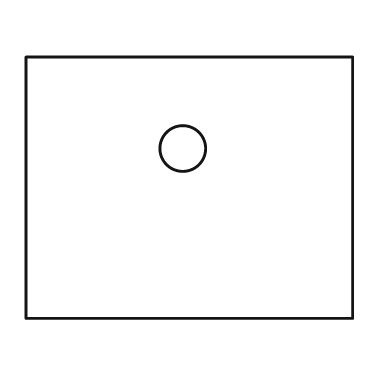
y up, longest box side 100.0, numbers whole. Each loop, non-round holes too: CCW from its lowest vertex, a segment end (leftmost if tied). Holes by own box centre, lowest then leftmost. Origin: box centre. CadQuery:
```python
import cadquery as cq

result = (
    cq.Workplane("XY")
    .moveTo(-50.0, -40.0)
    .lineTo(50.0, -40.0)
    .lineTo(50.0, 40.0)
    .lineTo(-50.0, 40.0)
    .close()
    .moveTo(-2.0, 12.0)
    .circle(7.0)
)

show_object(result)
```